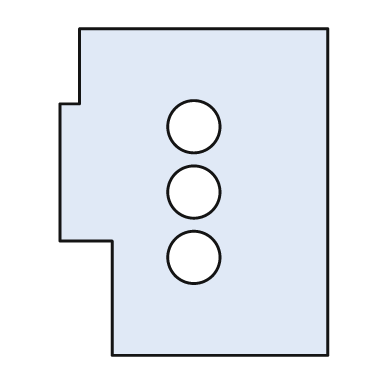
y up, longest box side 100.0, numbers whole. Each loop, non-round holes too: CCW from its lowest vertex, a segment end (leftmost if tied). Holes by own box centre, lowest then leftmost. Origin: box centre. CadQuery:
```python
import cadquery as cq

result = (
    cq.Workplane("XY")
    .moveTo(-25.0, -50.0)
    .lineTo(41.0, -50.0)
    .lineTo(41.0, 50.0)
    .lineTo(-35.0, 50.0)
    .lineTo(-35.0, 27.0)
    .lineTo(-41.0, 27.0)
    .lineTo(-41.0, -15.0)
    .lineTo(-25.0, -15.0)
    .close()
    .moveTo(0.0, -20.0)
    .circle(8.0)
    .moveTo(0.0, 0.0)
    .circle(8.0)
    .moveTo(0.0, 20.0)
    .circle(8.0)
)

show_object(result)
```